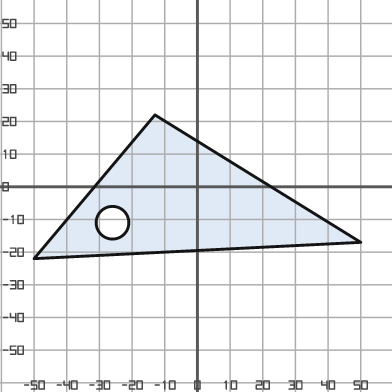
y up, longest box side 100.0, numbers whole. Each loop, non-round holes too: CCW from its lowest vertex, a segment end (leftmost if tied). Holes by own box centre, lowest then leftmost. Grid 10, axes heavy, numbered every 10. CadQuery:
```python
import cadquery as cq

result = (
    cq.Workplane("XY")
    .moveTo(-50.0, -22.0)
    .lineTo(50.0, -17.0)
    .lineTo(-13.0, 22.0)
    .close()
    .moveTo(-26.0, -11.0)
    .circle(5.0)
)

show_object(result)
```